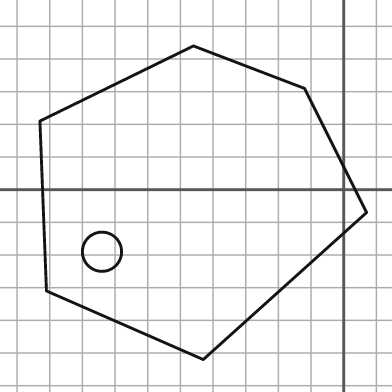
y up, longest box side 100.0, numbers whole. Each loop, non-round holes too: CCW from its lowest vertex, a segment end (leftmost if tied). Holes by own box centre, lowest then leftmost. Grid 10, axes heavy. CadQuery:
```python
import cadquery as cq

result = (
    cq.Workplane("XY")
    .moveTo(-43.0, -52.0)
    .lineTo(7.0, -7.0)
    .lineTo(-12.0, 31.0)
    .lineTo(-46.0, 44.0)
    .lineTo(-93.0, 21.0)
    .lineTo(-91.0, -31.0)
    .close()
    .moveTo(-74.0, -19.0)
    .circle(6.0)
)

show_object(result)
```